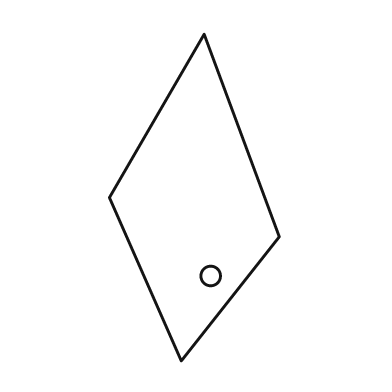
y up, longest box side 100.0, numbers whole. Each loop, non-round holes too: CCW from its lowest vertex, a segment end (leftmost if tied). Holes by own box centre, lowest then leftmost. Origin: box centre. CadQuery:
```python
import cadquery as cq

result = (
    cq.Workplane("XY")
    .moveTo(-4.0, -50.0)
    .lineTo(26.0, -12.0)
    .lineTo(3.0, 50.0)
    .lineTo(-26.0, 0.0)
    .close()
    .moveTo(5.0, -24.0)
    .circle(3.0)
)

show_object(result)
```